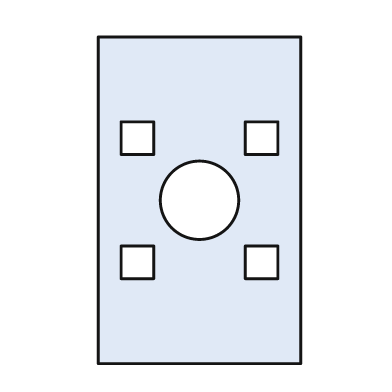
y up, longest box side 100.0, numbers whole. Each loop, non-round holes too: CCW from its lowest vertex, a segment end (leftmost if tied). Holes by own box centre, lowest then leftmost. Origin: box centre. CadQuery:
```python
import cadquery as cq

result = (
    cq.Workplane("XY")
    .moveTo(-31.0, -50.0)
    .lineTo(31.0, -50.0)
    .lineTo(31.0, 50.0)
    .lineTo(-31.0, 50.0)
    .close()
    .moveTo(-24.0, -24.0)
    .lineTo(-14.0, -24.0)
    .lineTo(-14.0, -14.0)
    .lineTo(-24.0, -14.0)
    .close()
    .moveTo(14.0, -24.0)
    .lineTo(24.0, -24.0)
    .lineTo(24.0, -14.0)
    .lineTo(14.0, -14.0)
    .close()
    .moveTo(0.0, 0.0)
    .circle(12.0)
    .moveTo(-24.0, 14.0)
    .lineTo(-14.0, 14.0)
    .lineTo(-14.0, 24.0)
    .lineTo(-24.0, 24.0)
    .close()
    .moveTo(14.0, 14.0)
    .lineTo(24.0, 14.0)
    .lineTo(24.0, 24.0)
    .lineTo(14.0, 24.0)
    .close()
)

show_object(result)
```